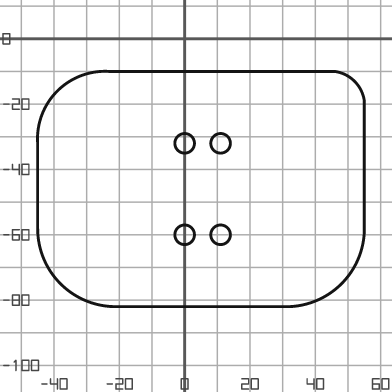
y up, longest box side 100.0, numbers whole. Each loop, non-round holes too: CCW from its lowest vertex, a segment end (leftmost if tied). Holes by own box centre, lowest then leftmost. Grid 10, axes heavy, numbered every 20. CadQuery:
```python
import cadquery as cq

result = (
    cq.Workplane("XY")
    .moveTo(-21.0, -82.0)
    .lineTo(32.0, -82.0)
    .threePointArc((48.0, -75.0), (55.0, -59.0))
    .lineTo(55.0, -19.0)
    .threePointArc((52.0, -13.0), (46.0, -10.0))
    .lineTo(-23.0, -10.0)
    .threePointArc((-39.0, -16.0), (-45.0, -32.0))
    .lineTo(-45.0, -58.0)
    .threePointArc((-38.0, -75.0), (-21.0, -82.0))
    .close()
    .moveTo(0.0, -60.0)
    .circle(3.0)
    .moveTo(11.0, -60.0)
    .circle(3.0)
    .moveTo(0.0, -32.0)
    .circle(3.0)
    .moveTo(11.0, -32.0)
    .circle(3.0)
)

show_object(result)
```